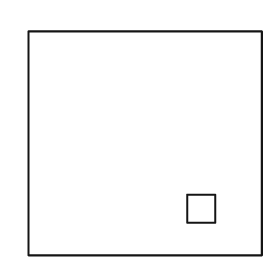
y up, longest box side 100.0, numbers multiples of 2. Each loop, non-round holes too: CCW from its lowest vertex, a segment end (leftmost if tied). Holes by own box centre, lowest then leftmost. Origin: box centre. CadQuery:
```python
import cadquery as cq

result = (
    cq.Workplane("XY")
    .moveTo(-50.0, -48.0)
    .lineTo(50.0, -48.0)
    .lineTo(50.0, 48.0)
    .lineTo(-50.0, 48.0)
    .close()
    .moveTo(18.0, -34.0)
    .lineTo(30.0, -34.0)
    .lineTo(30.0, -22.0)
    .lineTo(18.0, -22.0)
    .close()
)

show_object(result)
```